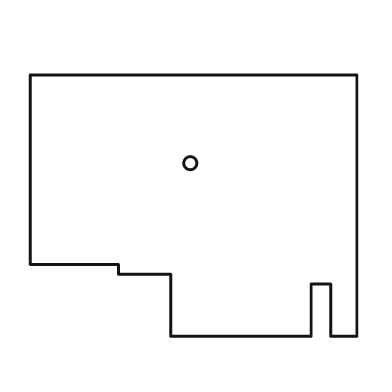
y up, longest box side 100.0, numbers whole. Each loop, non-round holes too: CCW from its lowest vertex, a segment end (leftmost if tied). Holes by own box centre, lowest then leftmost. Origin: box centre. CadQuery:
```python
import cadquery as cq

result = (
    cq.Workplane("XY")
    .moveTo(-7.0, -40.0)
    .lineTo(36.0, -40.0)
    .lineTo(36.0, -24.0)
    .lineTo(42.0, -24.0)
    .lineTo(42.0, -40.0)
    .lineTo(50.0, -40.0)
    .lineTo(50.0, 40.0)
    .lineTo(-50.0, 40.0)
    .lineTo(-50.0, -18.0)
    .lineTo(-23.0, -18.0)
    .lineTo(-23.0, -21.0)
    .lineTo(-7.0, -21.0)
    .close()
    .moveTo(-1.0, 13.0)
    .circle(2.0)
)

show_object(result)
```